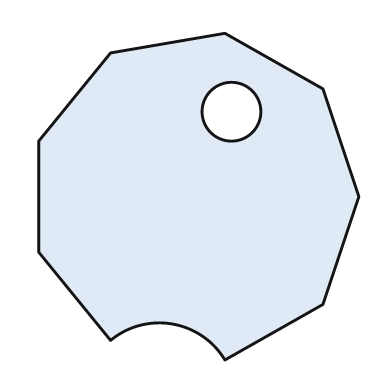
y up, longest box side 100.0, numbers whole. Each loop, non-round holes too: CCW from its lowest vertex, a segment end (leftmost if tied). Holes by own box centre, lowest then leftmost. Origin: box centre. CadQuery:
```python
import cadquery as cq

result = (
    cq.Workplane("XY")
    .moveTo(8.0, -50.0)
    .lineTo(38.0, -33.0)
    .lineTo(49.0, 0.0)
    .lineTo(38.0, 33.0)
    .lineTo(8.0, 50.0)
    .lineTo(-27.0, 44.0)
    .lineTo(-49.0, 17.0)
    .lineTo(-49.0, -17.0)
    .lineTo(-27.0, -44.0)
    .threePointArc((-8.0, -39.0), (8.0, -50.0))
    .close()
    .moveTo(10.0, 26.0)
    .circle(9.0)
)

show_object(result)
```